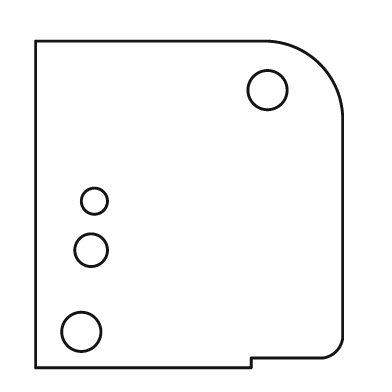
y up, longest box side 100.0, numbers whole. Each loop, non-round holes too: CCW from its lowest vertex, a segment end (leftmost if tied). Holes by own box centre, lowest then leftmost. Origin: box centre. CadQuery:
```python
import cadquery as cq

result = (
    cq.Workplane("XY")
    .moveTo(-47.0, -50.0)
    .lineTo(19.0, -50.0)
    .lineTo(19.0, -47.0)
    .lineTo(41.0, -47.0)
    .threePointArc((45.0, -45.0), (47.0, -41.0))
    .lineTo(47.0, 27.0)
    .threePointArc((40.0, 43.0), (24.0, 50.0))
    .lineTo(-47.0, 50.0)
    .close()
    .moveTo(-33.0, -39.0)
    .circle(6.0)
    .moveTo(-30.0, -14.0)
    .circle(5.0)
    .moveTo(-29.0, 1.0)
    .circle(4.0)
    .moveTo(24.0, 35.0)
    .circle(6.0)
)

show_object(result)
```